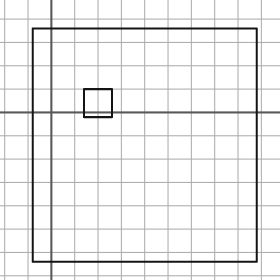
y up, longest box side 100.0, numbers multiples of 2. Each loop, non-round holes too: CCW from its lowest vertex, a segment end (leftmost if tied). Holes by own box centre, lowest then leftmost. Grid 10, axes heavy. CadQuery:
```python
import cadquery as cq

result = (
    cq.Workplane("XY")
    .moveTo(-8.0, -64.0)
    .lineTo(88.0, -64.0)
    .lineTo(88.0, 36.0)
    .lineTo(-8.0, 36.0)
    .close()
    .moveTo(14.0, -2.0)
    .lineTo(26.0, -2.0)
    .lineTo(26.0, 10.0)
    .lineTo(14.0, 10.0)
    .close()
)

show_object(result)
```